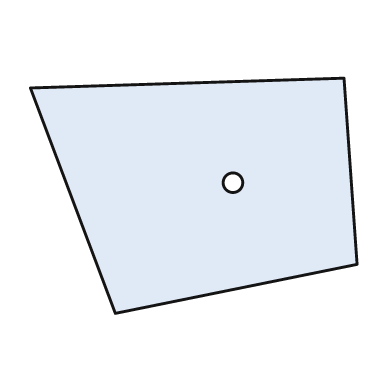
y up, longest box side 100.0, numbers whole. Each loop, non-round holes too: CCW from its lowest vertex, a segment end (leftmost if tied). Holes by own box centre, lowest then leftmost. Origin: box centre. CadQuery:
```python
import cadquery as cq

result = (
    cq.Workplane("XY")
    .moveTo(-24.0, -36.0)
    .lineTo(50.0, -21.0)
    .lineTo(46.0, 36.0)
    .lineTo(-50.0, 33.0)
    .close()
    .moveTo(12.0, 4.0)
    .circle(3.0)
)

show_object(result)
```